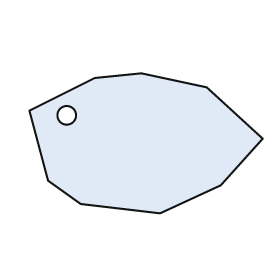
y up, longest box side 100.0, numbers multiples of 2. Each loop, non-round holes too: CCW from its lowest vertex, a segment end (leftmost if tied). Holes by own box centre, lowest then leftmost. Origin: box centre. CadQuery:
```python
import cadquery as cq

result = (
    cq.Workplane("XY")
    .moveTo(6.0, -30.0)
    .lineTo(32.0, -18.0)
    .lineTo(50.0, 2.0)
    .lineTo(26.0, 24.0)
    .lineTo(-2.0, 30.0)
    .lineTo(-22.0, 28.0)
    .lineTo(-50.0, 14.0)
    .lineTo(-42.0, -16.0)
    .lineTo(-28.0, -26.0)
    .close()
    .moveTo(-34.0, 12.0)
    .circle(4.0)
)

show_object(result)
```